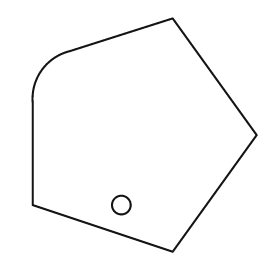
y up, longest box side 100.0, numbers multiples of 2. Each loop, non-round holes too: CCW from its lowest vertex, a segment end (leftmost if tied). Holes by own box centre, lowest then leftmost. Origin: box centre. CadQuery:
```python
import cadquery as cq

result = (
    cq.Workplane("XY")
    .moveTo(12.0, -50.0)
    .lineTo(48.0, 0.0)
    .lineTo(12.0, 50.0)
    .lineTo(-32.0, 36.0)
    .threePointArc((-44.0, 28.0), (-48.0, 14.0))
    .lineTo(-48.0, -30.0)
    .close()
    .moveTo(-10.0, -30.0)
    .circle(4.0)
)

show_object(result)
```